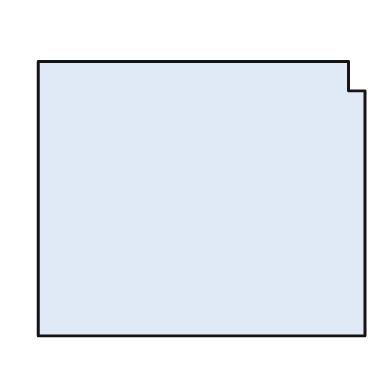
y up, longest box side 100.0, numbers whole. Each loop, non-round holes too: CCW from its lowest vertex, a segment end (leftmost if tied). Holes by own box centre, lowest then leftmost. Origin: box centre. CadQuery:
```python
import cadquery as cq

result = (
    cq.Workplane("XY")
    .moveTo(-50.0, -42.0)
    .lineTo(50.0, -42.0)
    .lineTo(50.0, 33.0)
    .lineTo(45.0, 33.0)
    .lineTo(45.0, 42.0)
    .lineTo(-50.0, 42.0)
    .close()
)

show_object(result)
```